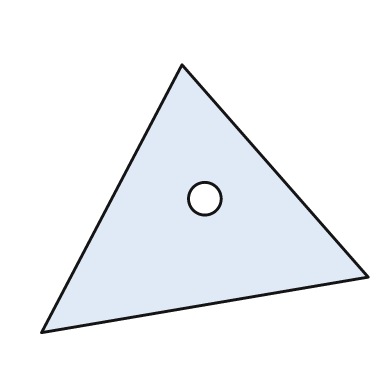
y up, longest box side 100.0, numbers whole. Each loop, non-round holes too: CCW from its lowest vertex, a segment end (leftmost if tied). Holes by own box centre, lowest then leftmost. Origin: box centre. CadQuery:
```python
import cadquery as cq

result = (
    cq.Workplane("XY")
    .moveTo(-50.0, -41.0)
    .lineTo(50.0, -24.0)
    .lineTo(-7.0, 41.0)
    .close()
    .moveTo(0.0, 0.0)
    .circle(5.0)
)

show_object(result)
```